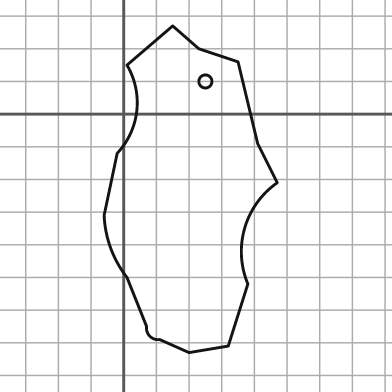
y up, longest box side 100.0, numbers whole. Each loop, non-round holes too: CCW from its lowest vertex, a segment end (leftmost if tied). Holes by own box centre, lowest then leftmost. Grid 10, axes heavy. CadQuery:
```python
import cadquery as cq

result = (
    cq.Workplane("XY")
    .moveTo(20.0, -73.0)
    .lineTo(32.0, -71.0)
    .lineTo(38.0, -52.0)
    .threePointArc((37.0, -35.0), (47.0, -21.0))
    .lineTo(41.0, -9.0)
    .lineTo(35.0, 16.0)
    .lineTo(23.0, 20.0)
    .lineTo(15.0, 27.0)
    .lineTo(1.0, 15.0)
    .threePointArc((4.0, 1.0), (-2.0, -12.0))
    .lineTo(-6.0, -31.0)
    .threePointArc((-4.0, -41.0), (1.0, -50.0))
    .lineTo(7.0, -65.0)
    .threePointArc((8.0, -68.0), (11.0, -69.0))
    .close()
    .moveTo(25.0, 10.0)
    .circle(2.0)
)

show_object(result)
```